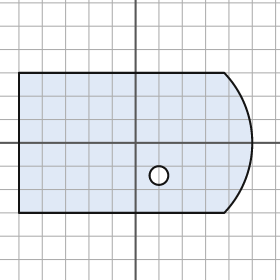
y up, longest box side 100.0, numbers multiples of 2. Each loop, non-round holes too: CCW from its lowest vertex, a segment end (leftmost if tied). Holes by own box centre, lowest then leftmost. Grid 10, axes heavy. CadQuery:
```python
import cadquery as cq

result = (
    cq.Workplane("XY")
    .moveTo(-50.0, -30.0)
    .lineTo(38.0, -30.0)
    .threePointArc((50.0, 0.0), (38.0, 30.0))
    .lineTo(-50.0, 30.0)
    .close()
    .moveTo(10.0, -14.0)
    .circle(4.0)
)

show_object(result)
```